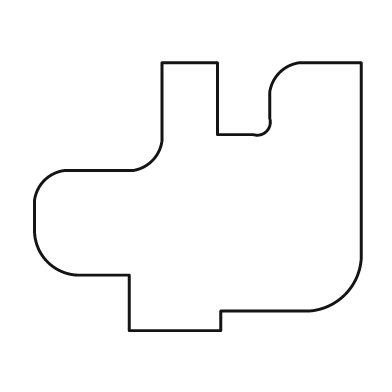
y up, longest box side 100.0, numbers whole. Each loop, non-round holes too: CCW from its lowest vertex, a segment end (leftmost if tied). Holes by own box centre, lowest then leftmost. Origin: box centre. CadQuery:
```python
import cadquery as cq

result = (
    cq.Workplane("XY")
    .moveTo(-21.0, -41.0)
    .lineTo(7.0, -41.0)
    .lineTo(7.0, -35.0)
    .lineTo(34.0, -35.0)
    .threePointArc((45.0, -30.0), (50.0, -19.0))
    .lineTo(50.0, 41.0)
    .lineTo(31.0, 41.0)
    .threePointArc((25.0, 38.0), (22.0, 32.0))
    .lineTo(22.0, 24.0)
    .threePointArc((21.0, 20.0), (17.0, 19.0))
    .lineTo(6.0, 19.0)
    .lineTo(6.0, 41.0)
    .lineTo(-11.0, 41.0)
    .lineTo(-11.0, 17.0)
    .threePointArc((-14.0, 11.0), (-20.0, 8.0))
    .lineTo(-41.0, 8.0)
    .threePointArc((-47.0, 5.0), (-50.0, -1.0))
    .lineTo(-50.0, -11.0)
    .threePointArc((-46.0, -20.0), (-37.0, -24.0))
    .lineTo(-21.0, -24.0)
    .close()
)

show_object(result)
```